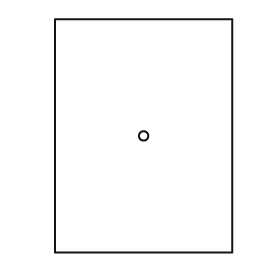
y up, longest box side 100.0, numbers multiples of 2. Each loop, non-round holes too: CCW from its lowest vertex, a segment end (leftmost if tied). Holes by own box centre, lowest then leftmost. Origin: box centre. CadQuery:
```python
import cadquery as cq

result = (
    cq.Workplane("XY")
    .moveTo(-38.0, -50.0)
    .lineTo(38.0, -50.0)
    .lineTo(38.0, 50.0)
    .lineTo(-38.0, 50.0)
    .close()
    .moveTo(0.0, 0.0)
    .circle(2.0)
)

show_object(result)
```